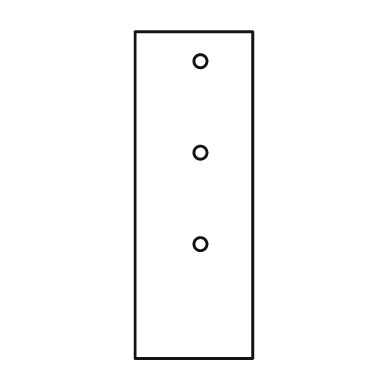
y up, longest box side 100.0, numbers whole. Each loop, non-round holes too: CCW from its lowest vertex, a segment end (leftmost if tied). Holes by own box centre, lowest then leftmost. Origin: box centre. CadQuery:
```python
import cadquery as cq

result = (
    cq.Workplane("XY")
    .moveTo(-18.0, -50.0)
    .lineTo(18.0, -50.0)
    .lineTo(18.0, 50.0)
    .lineTo(-18.0, 50.0)
    .close()
    .moveTo(2.0, -15.0)
    .circle(2.0)
    .moveTo(2.0, 13.0)
    .circle(2.0)
    .moveTo(2.0, 41.0)
    .circle(2.0)
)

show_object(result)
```